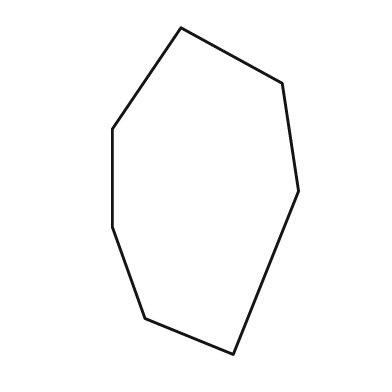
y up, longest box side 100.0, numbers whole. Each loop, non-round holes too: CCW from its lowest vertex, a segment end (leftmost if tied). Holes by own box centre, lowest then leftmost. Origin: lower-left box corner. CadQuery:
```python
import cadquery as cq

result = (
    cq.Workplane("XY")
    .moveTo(37.0, 0.0)
    .lineTo(57.0, 50.0)
    .lineTo(52.0, 83.0)
    .lineTo(21.0, 100.0)
    .lineTo(0.0, 69.0)
    .lineTo(0.0, 39.0)
    .lineTo(10.0, 11.0)
    .close()
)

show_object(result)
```